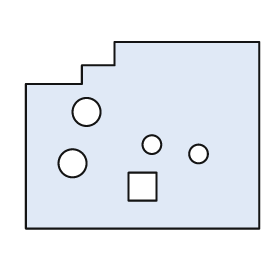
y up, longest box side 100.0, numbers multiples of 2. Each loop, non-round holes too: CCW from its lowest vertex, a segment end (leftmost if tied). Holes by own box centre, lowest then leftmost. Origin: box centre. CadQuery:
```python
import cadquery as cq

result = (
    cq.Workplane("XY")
    .moveTo(-50.0, -40.0)
    .lineTo(50.0, -40.0)
    .lineTo(50.0, 40.0)
    .lineTo(-12.0, 40.0)
    .lineTo(-12.0, 30.0)
    .lineTo(-26.0, 30.0)
    .lineTo(-26.0, 22.0)
    .lineTo(-50.0, 22.0)
    .close()
    .moveTo(-6.0, -28.0)
    .lineTo(6.0, -28.0)
    .lineTo(6.0, -16.0)
    .lineTo(-6.0, -16.0)
    .close()
    .moveTo(-30.0, -12.0)
    .circle(6.0)
    .moveTo(24.0, -8.0)
    .circle(4.0)
    .moveTo(4.0, -4.0)
    .circle(4.0)
    .moveTo(-24.0, 10.0)
    .circle(6.0)
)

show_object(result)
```